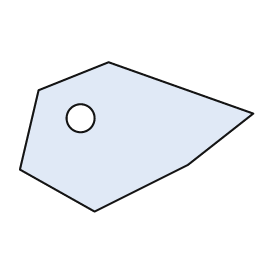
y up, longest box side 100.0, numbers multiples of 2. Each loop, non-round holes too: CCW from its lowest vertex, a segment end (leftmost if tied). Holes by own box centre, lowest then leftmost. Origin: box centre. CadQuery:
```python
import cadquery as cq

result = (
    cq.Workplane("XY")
    .moveTo(-18.0, -32.0)
    .lineTo(22.0, -12.0)
    .lineTo(50.0, 10.0)
    .lineTo(-12.0, 32.0)
    .lineTo(-42.0, 20.0)
    .lineTo(-50.0, -14.0)
    .close()
    .moveTo(-24.0, 8.0)
    .circle(6.0)
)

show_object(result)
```